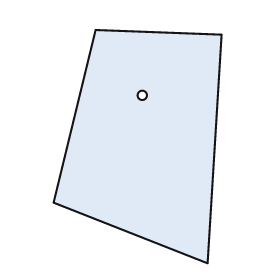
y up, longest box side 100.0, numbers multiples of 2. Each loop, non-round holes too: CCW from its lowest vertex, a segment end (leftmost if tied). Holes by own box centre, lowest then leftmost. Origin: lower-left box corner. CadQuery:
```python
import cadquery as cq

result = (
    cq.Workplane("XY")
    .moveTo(66.0, 0.0)
    .lineTo(72.0, 98.0)
    .lineTo(18.0, 100.0)
    .lineTo(0.0, 26.0)
    .close()
    .moveTo(38.0, 72.0)
    .circle(2.0)
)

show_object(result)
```